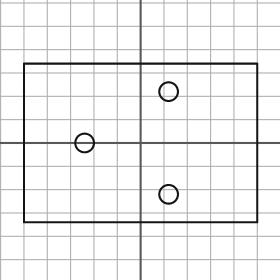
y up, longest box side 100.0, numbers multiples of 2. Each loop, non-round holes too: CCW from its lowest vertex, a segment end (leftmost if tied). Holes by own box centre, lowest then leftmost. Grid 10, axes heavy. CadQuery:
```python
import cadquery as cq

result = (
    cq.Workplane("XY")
    .moveTo(-50.0, -34.0)
    .lineTo(50.0, -34.0)
    .lineTo(50.0, 34.0)
    .lineTo(-50.0, 34.0)
    .close()
    .moveTo(12.0, -22.0)
    .circle(4.0)
    .moveTo(-24.0, 0.0)
    .circle(4.0)
    .moveTo(12.0, 22.0)
    .circle(4.0)
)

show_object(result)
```